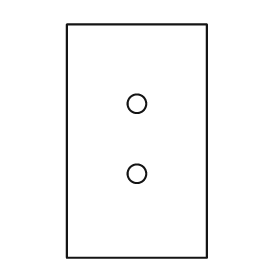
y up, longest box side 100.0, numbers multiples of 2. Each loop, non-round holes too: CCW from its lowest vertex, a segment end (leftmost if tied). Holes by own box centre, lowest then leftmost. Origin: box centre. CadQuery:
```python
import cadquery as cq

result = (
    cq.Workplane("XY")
    .moveTo(-30.0, -50.0)
    .lineTo(30.0, -50.0)
    .lineTo(30.0, 50.0)
    .lineTo(-30.0, 50.0)
    .close()
    .moveTo(0.0, -14.0)
    .circle(4.0)
    .moveTo(0.0, 16.0)
    .circle(4.0)
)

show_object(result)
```